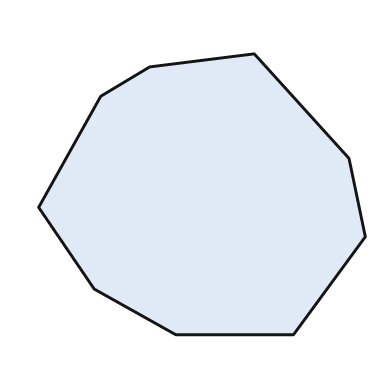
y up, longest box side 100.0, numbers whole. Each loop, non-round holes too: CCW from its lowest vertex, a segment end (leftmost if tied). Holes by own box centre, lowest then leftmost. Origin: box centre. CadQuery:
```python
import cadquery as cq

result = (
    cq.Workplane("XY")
    .moveTo(-8.0, -43.0)
    .lineTo(28.0, -43.0)
    .lineTo(50.0, -13.0)
    .lineTo(45.0, 11.0)
    .lineTo(16.0, 43.0)
    .lineTo(-16.0, 39.0)
    .lineTo(-31.0, 30.0)
    .lineTo(-50.0, -4.0)
    .lineTo(-33.0, -29.0)
    .close()
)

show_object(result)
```